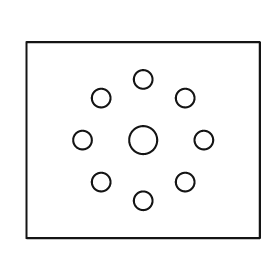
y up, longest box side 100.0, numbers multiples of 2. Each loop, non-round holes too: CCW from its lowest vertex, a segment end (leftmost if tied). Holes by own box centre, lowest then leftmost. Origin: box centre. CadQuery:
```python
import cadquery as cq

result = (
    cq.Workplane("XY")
    .moveTo(-50.0, -42.0)
    .lineTo(50.0, -42.0)
    .lineTo(50.0, 42.0)
    .lineTo(-50.0, 42.0)
    .close()
    .moveTo(0.0, -26.0)
    .circle(4.0)
    .moveTo(-18.0, -18.0)
    .circle(4.0)
    .moveTo(18.0, -18.0)
    .circle(4.0)
    .moveTo(-26.0, 0.0)
    .circle(4.0)
    .moveTo(0.0, 0.0)
    .circle(6.0)
    .moveTo(26.0, 0.0)
    .circle(4.0)
    .moveTo(-18.0, 18.0)
    .circle(4.0)
    .moveTo(18.0, 18.0)
    .circle(4.0)
    .moveTo(0.0, 26.0)
    .circle(4.0)
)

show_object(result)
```